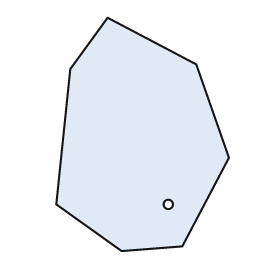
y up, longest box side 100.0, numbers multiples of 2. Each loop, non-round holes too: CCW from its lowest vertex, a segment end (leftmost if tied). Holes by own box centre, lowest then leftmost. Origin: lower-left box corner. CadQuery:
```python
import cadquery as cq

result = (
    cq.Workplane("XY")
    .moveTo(28.0, 0.0)
    .lineTo(54.0, 2.0)
    .lineTo(74.0, 40.0)
    .lineTo(60.0, 80.0)
    .lineTo(22.0, 100.0)
    .lineTo(6.0, 78.0)
    .lineTo(0.0, 20.0)
    .close()
    .moveTo(48.0, 20.0)
    .circle(2.0)
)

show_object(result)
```